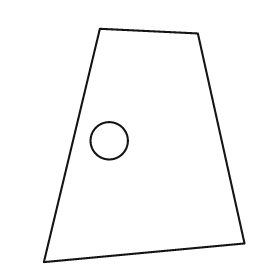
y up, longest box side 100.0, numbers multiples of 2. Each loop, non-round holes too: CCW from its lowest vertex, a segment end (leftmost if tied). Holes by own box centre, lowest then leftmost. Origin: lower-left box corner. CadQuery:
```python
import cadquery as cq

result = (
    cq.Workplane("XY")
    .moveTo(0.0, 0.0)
    .lineTo(86.0, 8.0)
    .lineTo(66.0, 98.0)
    .lineTo(24.0, 100.0)
    .close()
    .moveTo(28.0, 52.0)
    .circle(8.0)
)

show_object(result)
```